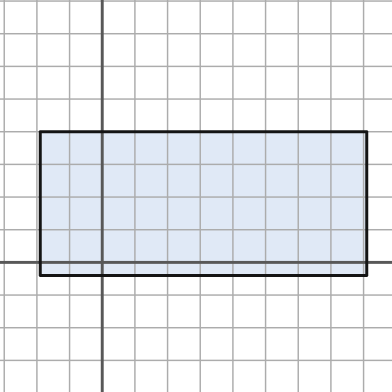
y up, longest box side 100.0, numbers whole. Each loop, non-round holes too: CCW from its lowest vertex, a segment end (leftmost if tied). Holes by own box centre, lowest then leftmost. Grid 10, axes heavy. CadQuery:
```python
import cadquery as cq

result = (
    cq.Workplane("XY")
    .moveTo(-19.0, -4.0)
    .lineTo(81.0, -4.0)
    .lineTo(81.0, 40.0)
    .lineTo(-19.0, 40.0)
    .close()
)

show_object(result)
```